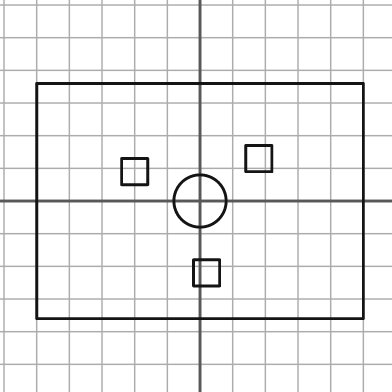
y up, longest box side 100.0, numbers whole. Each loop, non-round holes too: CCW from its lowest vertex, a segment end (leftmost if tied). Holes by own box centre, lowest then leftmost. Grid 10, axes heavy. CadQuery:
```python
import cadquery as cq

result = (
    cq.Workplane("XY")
    .moveTo(-50.0, -36.0)
    .lineTo(50.0, -36.0)
    .lineTo(50.0, 36.0)
    .lineTo(-50.0, 36.0)
    .close()
    .moveTo(-2.0, -26.0)
    .lineTo(6.0, -26.0)
    .lineTo(6.0, -18.0)
    .lineTo(-2.0, -18.0)
    .close()
    .moveTo(0.0, 0.0)
    .circle(8.0)
    .moveTo(-24.0, 5.0)
    .lineTo(-16.0, 5.0)
    .lineTo(-16.0, 13.0)
    .lineTo(-24.0, 13.0)
    .close()
    .moveTo(14.0, 9.0)
    .lineTo(22.0, 9.0)
    .lineTo(22.0, 17.0)
    .lineTo(14.0, 17.0)
    .close()
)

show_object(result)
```